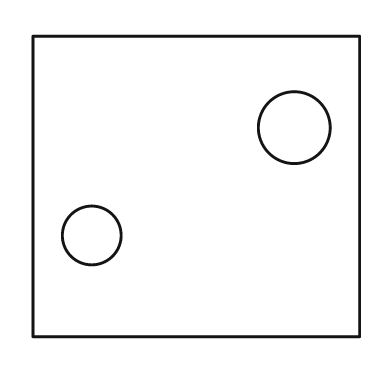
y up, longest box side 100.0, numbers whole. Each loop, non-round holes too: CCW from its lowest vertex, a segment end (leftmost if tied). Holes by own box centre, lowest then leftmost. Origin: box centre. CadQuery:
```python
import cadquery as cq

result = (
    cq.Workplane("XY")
    .moveTo(-50.0, -46.0)
    .lineTo(50.0, -46.0)
    .lineTo(50.0, 46.0)
    .lineTo(-50.0, 46.0)
    .close()
    .moveTo(-32.0, -15.0)
    .circle(9.0)
    .moveTo(30.0, 18.0)
    .circle(11.0)
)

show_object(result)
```